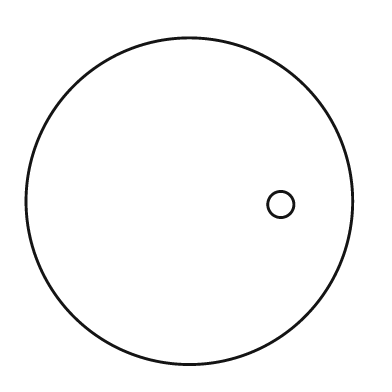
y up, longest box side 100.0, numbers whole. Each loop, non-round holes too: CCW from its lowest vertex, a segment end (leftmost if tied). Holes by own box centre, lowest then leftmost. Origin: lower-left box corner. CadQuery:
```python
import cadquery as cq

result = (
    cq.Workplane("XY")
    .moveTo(50.0, 50.0)
    .circle(50.0)
    .moveTo(78.0, 49.0)
    .circle(4.0)
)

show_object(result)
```